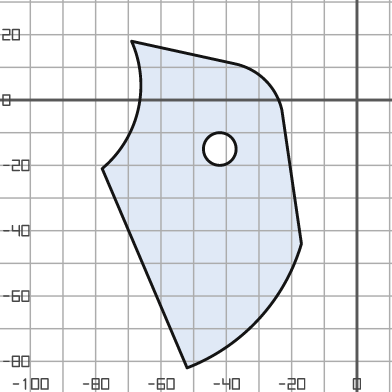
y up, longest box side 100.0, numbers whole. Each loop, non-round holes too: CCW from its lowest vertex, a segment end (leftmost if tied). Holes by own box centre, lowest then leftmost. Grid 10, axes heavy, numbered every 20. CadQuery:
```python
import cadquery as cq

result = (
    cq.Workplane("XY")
    .moveTo(-52.0, -82.0)
    .threePointArc((-30.0, -67.0), (-17.0, -44.0))
    .lineTo(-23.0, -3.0)
    .threePointArc((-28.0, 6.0), (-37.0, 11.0))
    .lineTo(-69.0, 18.0)
    .threePointArc((-67.0, -3.0), (-78.0, -21.0))
    .close()
    .moveTo(-42.0, -15.0)
    .circle(5.0)
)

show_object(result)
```